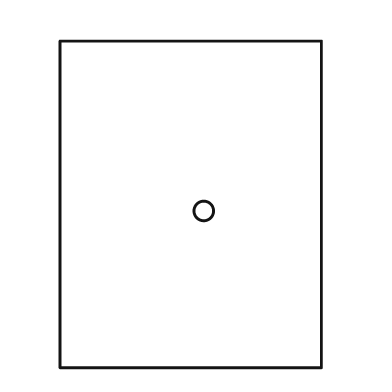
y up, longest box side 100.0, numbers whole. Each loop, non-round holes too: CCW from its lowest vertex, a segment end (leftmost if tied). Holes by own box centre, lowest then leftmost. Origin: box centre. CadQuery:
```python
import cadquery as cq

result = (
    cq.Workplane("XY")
    .moveTo(-40.0, -50.0)
    .lineTo(40.0, -50.0)
    .lineTo(40.0, 50.0)
    .lineTo(-40.0, 50.0)
    .close()
    .moveTo(4.0, -2.0)
    .circle(3.0)
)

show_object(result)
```